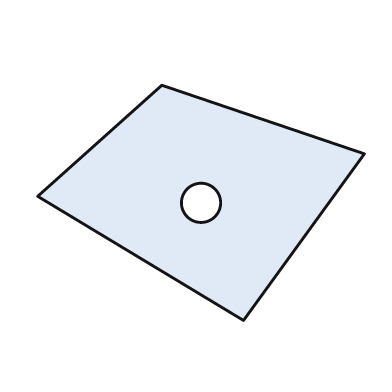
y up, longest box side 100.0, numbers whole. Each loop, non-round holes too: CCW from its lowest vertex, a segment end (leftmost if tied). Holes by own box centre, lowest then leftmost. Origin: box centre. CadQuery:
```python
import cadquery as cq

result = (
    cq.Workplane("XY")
    .moveTo(13.0, -36.0)
    .lineTo(50.0, 15.0)
    .lineTo(-12.0, 36.0)
    .lineTo(-50.0, 2.0)
    .close()
    .moveTo(0.0, 0.0)
    .circle(6.0)
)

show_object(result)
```